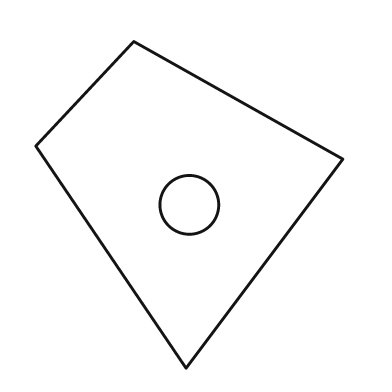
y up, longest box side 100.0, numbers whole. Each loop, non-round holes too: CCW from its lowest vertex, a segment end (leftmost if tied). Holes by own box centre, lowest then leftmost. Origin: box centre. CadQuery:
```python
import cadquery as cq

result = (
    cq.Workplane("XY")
    .moveTo(-1.0, -50.0)
    .lineTo(47.0, 14.0)
    .lineTo(-17.0, 50.0)
    .lineTo(-47.0, 18.0)
    .close()
    .moveTo(0.0, 0.0)
    .circle(9.0)
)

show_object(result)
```